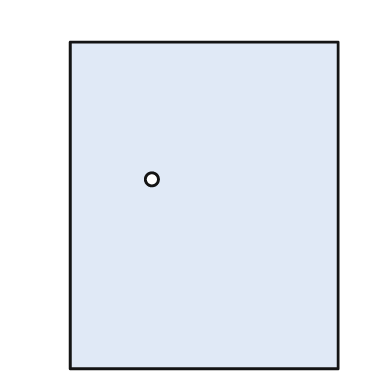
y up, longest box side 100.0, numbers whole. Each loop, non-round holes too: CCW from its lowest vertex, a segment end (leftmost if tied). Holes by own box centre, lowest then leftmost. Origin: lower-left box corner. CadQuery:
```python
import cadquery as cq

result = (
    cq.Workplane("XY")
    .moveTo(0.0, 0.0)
    .lineTo(82.0, 0.0)
    .lineTo(82.0, 100.0)
    .lineTo(0.0, 100.0)
    .close()
    .moveTo(25.0, 58.0)
    .circle(2.0)
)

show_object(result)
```